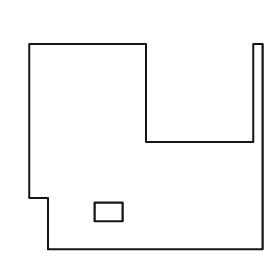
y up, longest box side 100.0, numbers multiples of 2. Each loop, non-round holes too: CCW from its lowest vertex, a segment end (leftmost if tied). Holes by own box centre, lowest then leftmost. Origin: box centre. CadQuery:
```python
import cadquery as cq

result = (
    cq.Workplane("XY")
    .moveTo(-42.0, -44.0)
    .lineTo(50.0, -44.0)
    .lineTo(50.0, 44.0)
    .lineTo(46.0, 44.0)
    .lineTo(46.0, 2.0)
    .lineTo(0.0, 2.0)
    .lineTo(0.0, 44.0)
    .lineTo(-50.0, 44.0)
    .lineTo(-50.0, -22.0)
    .lineTo(-42.0, -22.0)
    .close()
    .moveTo(-22.0, -32.0)
    .lineTo(-10.0, -32.0)
    .lineTo(-10.0, -24.0)
    .lineTo(-22.0, -24.0)
    .close()
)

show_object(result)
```